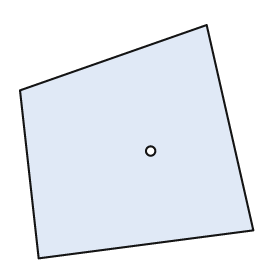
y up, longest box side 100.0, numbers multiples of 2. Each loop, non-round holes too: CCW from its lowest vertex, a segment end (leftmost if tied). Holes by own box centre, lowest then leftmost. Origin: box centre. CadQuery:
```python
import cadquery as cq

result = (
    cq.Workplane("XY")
    .moveTo(-42.0, -50.0)
    .lineTo(50.0, -38.0)
    .lineTo(30.0, 50.0)
    .lineTo(-50.0, 22.0)
    .close()
    .moveTo(6.0, -4.0)
    .circle(2.0)
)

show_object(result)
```